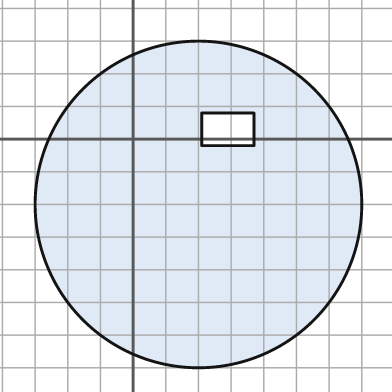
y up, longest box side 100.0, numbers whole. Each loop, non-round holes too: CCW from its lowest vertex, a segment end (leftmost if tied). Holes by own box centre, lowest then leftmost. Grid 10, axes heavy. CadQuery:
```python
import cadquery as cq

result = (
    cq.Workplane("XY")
    .moveTo(20.0, -20.0)
    .circle(50.0)
    .moveTo(21.0, -2.0)
    .lineTo(37.0, -2.0)
    .lineTo(37.0, 8.0)
    .lineTo(21.0, 8.0)
    .close()
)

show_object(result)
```